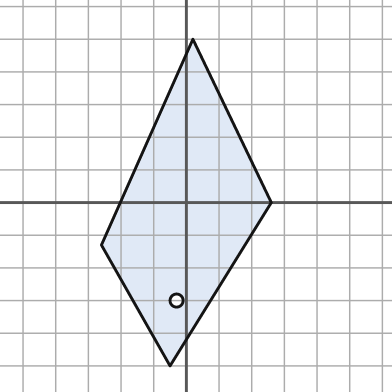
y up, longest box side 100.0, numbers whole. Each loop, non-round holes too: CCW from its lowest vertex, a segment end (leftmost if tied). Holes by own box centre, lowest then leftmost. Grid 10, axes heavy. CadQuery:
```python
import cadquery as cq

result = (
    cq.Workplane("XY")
    .moveTo(-5.0, -50.0)
    .lineTo(26.0, 0.0)
    .lineTo(2.0, 50.0)
    .lineTo(-26.0, -13.0)
    .close()
    .moveTo(-3.0, -30.0)
    .circle(2.0)
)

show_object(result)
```